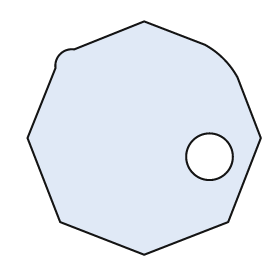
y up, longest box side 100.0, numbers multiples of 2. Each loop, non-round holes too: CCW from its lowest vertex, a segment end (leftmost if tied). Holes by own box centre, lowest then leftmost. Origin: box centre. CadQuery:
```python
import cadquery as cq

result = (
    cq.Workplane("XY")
    .moveTo(0.0, -50.0)
    .lineTo(36.0, -36.0)
    .lineTo(50.0, 0.0)
    .lineTo(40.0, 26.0)
    .threePointArc((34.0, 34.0), (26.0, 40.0))
    .lineTo(0.0, 50.0)
    .lineTo(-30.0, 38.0)
    .threePointArc((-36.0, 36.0), (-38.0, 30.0))
    .lineTo(-50.0, 0.0)
    .lineTo(-36.0, -36.0)
    .close()
    .moveTo(28.0, -8.0)
    .circle(10.0)
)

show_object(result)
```